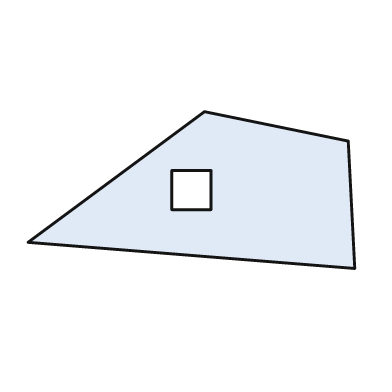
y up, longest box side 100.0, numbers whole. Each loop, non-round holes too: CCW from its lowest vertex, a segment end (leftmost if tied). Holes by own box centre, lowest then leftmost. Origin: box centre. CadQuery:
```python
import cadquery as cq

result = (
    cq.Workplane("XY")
    .moveTo(50.0, -24.0)
    .lineTo(48.0, 15.0)
    .lineTo(4.0, 24.0)
    .lineTo(-50.0, -16.0)
    .close()
    .moveTo(-6.0, -6.0)
    .lineTo(6.0, -6.0)
    .lineTo(6.0, 6.0)
    .lineTo(-6.0, 6.0)
    .close()
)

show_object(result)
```